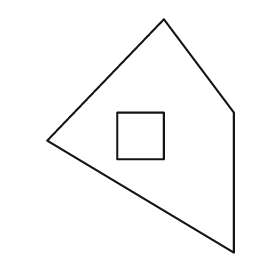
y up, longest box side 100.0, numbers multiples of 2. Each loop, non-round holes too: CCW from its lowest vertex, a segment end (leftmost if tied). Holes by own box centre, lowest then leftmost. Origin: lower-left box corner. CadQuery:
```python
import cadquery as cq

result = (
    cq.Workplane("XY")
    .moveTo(80.0, 0.0)
    .lineTo(80.0, 60.0)
    .lineTo(50.0, 100.0)
    .lineTo(0.0, 48.0)
    .close()
    .moveTo(30.0, 40.0)
    .lineTo(50.0, 40.0)
    .lineTo(50.0, 60.0)
    .lineTo(30.0, 60.0)
    .close()
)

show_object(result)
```